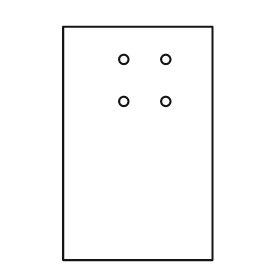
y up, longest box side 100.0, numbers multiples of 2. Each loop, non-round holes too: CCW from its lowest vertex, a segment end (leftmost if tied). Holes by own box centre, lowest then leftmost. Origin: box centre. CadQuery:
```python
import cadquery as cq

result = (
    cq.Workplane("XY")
    .moveTo(-32.0, -50.0)
    .lineTo(32.0, -50.0)
    .lineTo(32.0, 50.0)
    .lineTo(-32.0, 50.0)
    .close()
    .moveTo(-6.0, 18.0)
    .circle(2.0)
    .moveTo(12.0, 18.0)
    .circle(2.0)
    .moveTo(-6.0, 36.0)
    .circle(2.0)
    .moveTo(12.0, 36.0)
    .circle(2.0)
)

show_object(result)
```